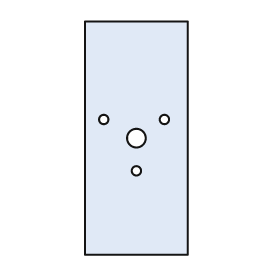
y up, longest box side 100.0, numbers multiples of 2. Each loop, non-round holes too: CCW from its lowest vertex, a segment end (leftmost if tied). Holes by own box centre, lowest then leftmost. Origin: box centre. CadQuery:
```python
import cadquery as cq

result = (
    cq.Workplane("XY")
    .moveTo(-22.0, -50.0)
    .lineTo(22.0, -50.0)
    .lineTo(22.0, 50.0)
    .lineTo(-22.0, 50.0)
    .close()
    .moveTo(0.0, -14.0)
    .circle(2.0)
    .moveTo(0.0, 0.0)
    .circle(4.0)
    .moveTo(-14.0, 8.0)
    .circle(2.0)
    .moveTo(12.0, 8.0)
    .circle(2.0)
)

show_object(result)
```